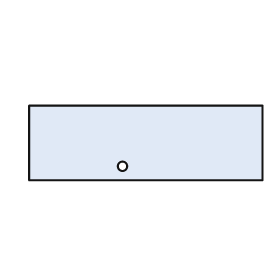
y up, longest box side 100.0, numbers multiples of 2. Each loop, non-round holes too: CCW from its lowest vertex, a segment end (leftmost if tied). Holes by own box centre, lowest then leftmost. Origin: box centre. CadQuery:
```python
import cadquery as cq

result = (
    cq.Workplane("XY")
    .moveTo(-50.0, -16.0)
    .lineTo(50.0, -16.0)
    .lineTo(50.0, 16.0)
    .lineTo(-50.0, 16.0)
    .close()
    .moveTo(-10.0, -10.0)
    .circle(2.0)
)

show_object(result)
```